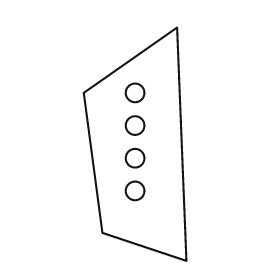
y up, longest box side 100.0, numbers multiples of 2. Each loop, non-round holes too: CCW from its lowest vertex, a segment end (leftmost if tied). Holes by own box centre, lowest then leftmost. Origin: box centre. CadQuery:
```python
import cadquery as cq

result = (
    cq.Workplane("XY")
    .moveTo(22.0, -50.0)
    .lineTo(18.0, 50.0)
    .lineTo(-22.0, 22.0)
    .lineTo(-14.0, -38.0)
    .close()
    .moveTo(0.0, -20.0)
    .circle(4.0)
    .moveTo(0.0, -6.0)
    .circle(4.0)
    .moveTo(0.0, 8.0)
    .circle(4.0)
    .moveTo(0.0, 22.0)
    .circle(4.0)
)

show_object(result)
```